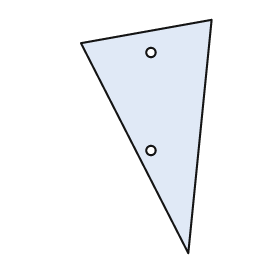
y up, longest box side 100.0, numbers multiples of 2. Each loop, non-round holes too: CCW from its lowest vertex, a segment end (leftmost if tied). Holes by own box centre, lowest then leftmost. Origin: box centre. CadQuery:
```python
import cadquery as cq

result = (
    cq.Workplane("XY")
    .moveTo(18.0, -50.0)
    .lineTo(28.0, 50.0)
    .lineTo(-28.0, 40.0)
    .close()
    .moveTo(2.0, -6.0)
    .circle(2.0)
    .moveTo(2.0, 36.0)
    .circle(2.0)
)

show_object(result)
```